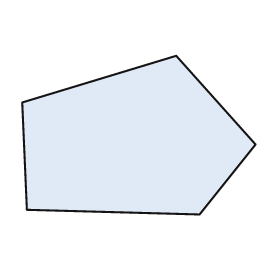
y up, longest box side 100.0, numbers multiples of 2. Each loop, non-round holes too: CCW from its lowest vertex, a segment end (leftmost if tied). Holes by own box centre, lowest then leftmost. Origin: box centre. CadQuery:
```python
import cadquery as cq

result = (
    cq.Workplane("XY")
    .moveTo(26.0, -34.0)
    .lineTo(50.0, -4.0)
    .lineTo(16.0, 34.0)
    .lineTo(-50.0, 14.0)
    .lineTo(-48.0, -32.0)
    .close()
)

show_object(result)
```